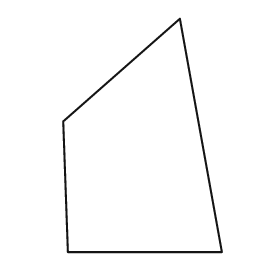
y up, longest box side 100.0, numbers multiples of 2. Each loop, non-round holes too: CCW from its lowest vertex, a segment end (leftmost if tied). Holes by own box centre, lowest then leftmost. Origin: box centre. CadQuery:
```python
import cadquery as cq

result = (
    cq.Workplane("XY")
    .moveTo(-32.0, -50.0)
    .lineTo(34.0, -50.0)
    .lineTo(16.0, 50.0)
    .lineTo(-34.0, 6.0)
    .close()
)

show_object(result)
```